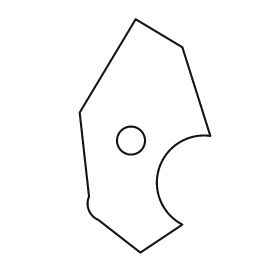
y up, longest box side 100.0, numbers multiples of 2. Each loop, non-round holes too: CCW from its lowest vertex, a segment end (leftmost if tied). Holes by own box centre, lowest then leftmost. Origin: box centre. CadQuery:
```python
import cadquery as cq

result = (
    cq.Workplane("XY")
    .moveTo(-2.0, -50.0)
    .lineTo(16.0, -38.0)
    .threePointArc((6.0, -14.0), (28.0, 0.0))
    .lineTo(16.0, 38.0)
    .lineTo(-4.0, 50.0)
    .lineTo(-28.0, 10.0)
    .lineTo(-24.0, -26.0)
    .threePointArc((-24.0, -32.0), (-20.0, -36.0))
    .close()
    .moveTo(-6.0, -2.0)
    .circle(6.0)
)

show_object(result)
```